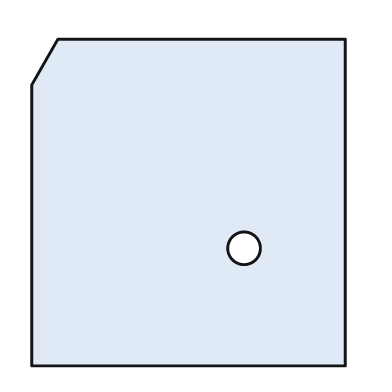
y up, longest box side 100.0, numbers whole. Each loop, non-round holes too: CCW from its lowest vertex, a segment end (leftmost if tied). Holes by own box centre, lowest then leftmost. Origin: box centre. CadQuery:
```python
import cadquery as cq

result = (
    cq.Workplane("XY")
    .moveTo(-48.0, -50.0)
    .lineTo(48.0, -50.0)
    .lineTo(48.0, 50.0)
    .lineTo(-40.0, 50.0)
    .lineTo(-48.0, 36.0)
    .close()
    .moveTo(17.0, -14.0)
    .circle(5.0)
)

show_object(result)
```